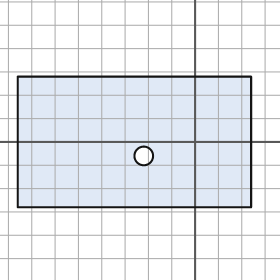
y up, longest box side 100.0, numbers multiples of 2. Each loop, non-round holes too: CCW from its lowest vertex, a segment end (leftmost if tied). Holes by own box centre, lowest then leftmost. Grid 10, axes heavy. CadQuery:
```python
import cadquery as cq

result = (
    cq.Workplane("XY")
    .moveTo(-76.0, -28.0)
    .lineTo(24.0, -28.0)
    .lineTo(24.0, 28.0)
    .lineTo(-76.0, 28.0)
    .close()
    .moveTo(-22.0, -6.0)
    .circle(4.0)
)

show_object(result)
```